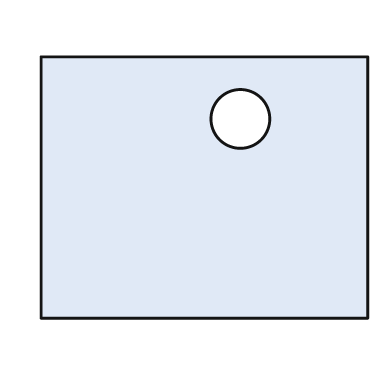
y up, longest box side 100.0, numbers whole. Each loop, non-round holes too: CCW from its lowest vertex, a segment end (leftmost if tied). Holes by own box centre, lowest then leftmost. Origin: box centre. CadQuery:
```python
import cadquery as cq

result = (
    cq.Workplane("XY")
    .moveTo(-50.0, -40.0)
    .lineTo(50.0, -40.0)
    .lineTo(50.0, 40.0)
    .lineTo(-50.0, 40.0)
    .close()
    .moveTo(11.0, 21.0)
    .circle(9.0)
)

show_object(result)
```